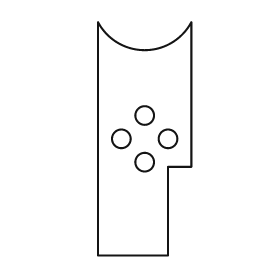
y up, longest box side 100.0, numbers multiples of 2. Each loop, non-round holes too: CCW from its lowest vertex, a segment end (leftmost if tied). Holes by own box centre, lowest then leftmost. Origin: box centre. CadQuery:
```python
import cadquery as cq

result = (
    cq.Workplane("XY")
    .moveTo(-20.0, -50.0)
    .lineTo(10.0, -50.0)
    .lineTo(10.0, -12.0)
    .lineTo(20.0, -12.0)
    .lineTo(20.0, 50.0)
    .threePointArc((0.0, 38.0), (-20.0, 50.0))
    .close()
    .moveTo(0.0, -10.0)
    .circle(4.0)
    .moveTo(-10.0, 0.0)
    .circle(4.0)
    .moveTo(10.0, 0.0)
    .circle(4.0)
    .moveTo(0.0, 10.0)
    .circle(4.0)
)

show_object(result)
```